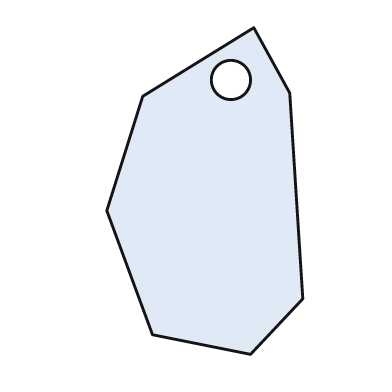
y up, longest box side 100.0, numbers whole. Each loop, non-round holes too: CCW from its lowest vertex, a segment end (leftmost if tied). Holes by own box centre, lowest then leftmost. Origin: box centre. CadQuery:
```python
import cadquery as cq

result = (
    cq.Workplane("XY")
    .moveTo(14.0, -50.0)
    .lineTo(30.0, -33.0)
    .lineTo(26.0, 30.0)
    .lineTo(15.0, 50.0)
    .lineTo(-19.0, 29.0)
    .lineTo(-30.0, -6.0)
    .lineTo(-16.0, -44.0)
    .close()
    .moveTo(8.0, 34.0)
    .circle(6.0)
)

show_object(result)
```